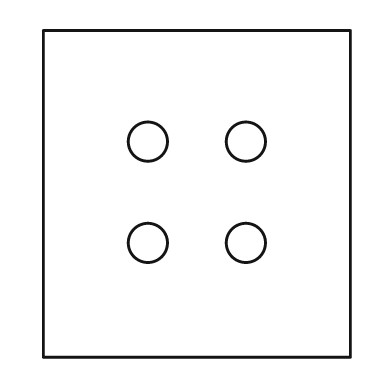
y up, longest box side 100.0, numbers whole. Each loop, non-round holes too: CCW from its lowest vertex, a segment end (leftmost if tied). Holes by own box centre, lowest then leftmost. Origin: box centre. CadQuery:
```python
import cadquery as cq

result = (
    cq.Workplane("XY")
    .moveTo(-47.0, -50.0)
    .lineTo(47.0, -50.0)
    .lineTo(47.0, 50.0)
    .lineTo(-47.0, 50.0)
    .close()
    .moveTo(-15.0, -15.0)
    .circle(6.0)
    .moveTo(15.0, -15.0)
    .circle(6.0)
    .moveTo(-15.0, 16.0)
    .circle(6.0)
    .moveTo(15.0, 16.0)
    .circle(6.0)
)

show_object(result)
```